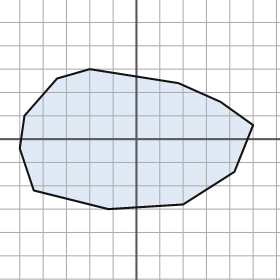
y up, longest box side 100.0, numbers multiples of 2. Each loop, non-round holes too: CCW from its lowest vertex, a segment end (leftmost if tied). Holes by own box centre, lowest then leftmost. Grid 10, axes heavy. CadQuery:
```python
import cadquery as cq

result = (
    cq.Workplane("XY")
    .moveTo(-12.0, -30.0)
    .lineTo(20.0, -28.0)
    .lineTo(42.0, -14.0)
    .lineTo(50.0, 6.0)
    .lineTo(36.0, 16.0)
    .lineTo(18.0, 24.0)
    .lineTo(-20.0, 30.0)
    .lineTo(-34.0, 26.0)
    .lineTo(-48.0, 10.0)
    .lineTo(-50.0, -4.0)
    .lineTo(-44.0, -22.0)
    .close()
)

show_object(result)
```